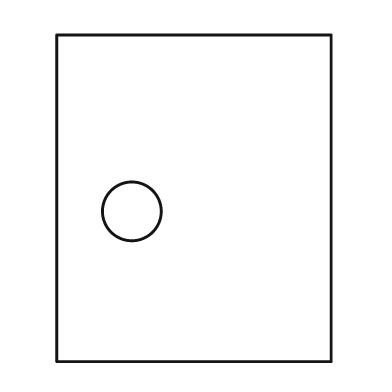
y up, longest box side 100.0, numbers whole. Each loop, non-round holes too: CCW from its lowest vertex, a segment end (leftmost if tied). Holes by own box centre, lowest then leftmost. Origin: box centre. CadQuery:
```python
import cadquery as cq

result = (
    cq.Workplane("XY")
    .moveTo(-42.0, -50.0)
    .lineTo(42.0, -50.0)
    .lineTo(42.0, 50.0)
    .lineTo(-42.0, 50.0)
    .close()
    .moveTo(-19.0, -4.0)
    .circle(9.0)
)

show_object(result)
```